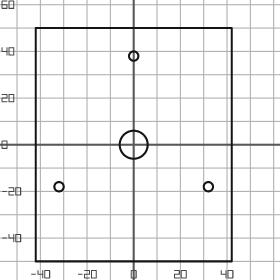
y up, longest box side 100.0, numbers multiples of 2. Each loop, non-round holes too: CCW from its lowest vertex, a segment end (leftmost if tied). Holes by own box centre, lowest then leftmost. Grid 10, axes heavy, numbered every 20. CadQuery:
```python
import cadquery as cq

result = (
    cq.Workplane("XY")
    .moveTo(-42.0, -50.0)
    .lineTo(42.0, -50.0)
    .lineTo(42.0, 50.0)
    .lineTo(-42.0, 50.0)
    .close()
    .moveTo(-32.0, -18.0)
    .circle(2.0)
    .moveTo(32.0, -18.0)
    .circle(2.0)
    .moveTo(0.0, 0.0)
    .circle(6.0)
    .moveTo(0.0, 38.0)
    .circle(2.0)
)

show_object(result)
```